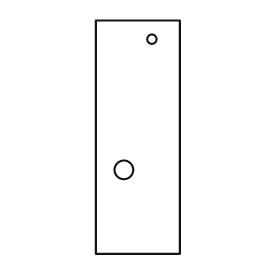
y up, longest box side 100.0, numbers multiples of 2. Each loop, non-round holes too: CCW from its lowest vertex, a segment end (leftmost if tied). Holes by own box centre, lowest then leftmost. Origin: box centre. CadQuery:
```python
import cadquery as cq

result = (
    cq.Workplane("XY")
    .moveTo(-18.0, -50.0)
    .lineTo(18.0, -50.0)
    .lineTo(18.0, 50.0)
    .lineTo(-18.0, 50.0)
    .close()
    .moveTo(-6.0, -14.0)
    .circle(4.0)
    .moveTo(6.0, 42.0)
    .circle(2.0)
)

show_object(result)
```